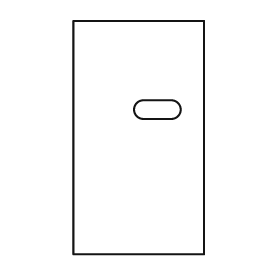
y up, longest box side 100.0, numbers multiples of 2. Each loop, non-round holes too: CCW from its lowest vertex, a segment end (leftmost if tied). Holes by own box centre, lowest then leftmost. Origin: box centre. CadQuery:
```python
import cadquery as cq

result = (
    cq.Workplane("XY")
    .moveTo(-28.0, -50.0)
    .lineTo(28.0, -50.0)
    .lineTo(28.0, 50.0)
    .lineTo(-28.0, 50.0)
    .close()
    .moveTo(2.0, 8.0)
    .lineTo(14.0, 8.0)
    .threePointArc((18.0, 12.0), (14.0, 16.0))
    .lineTo(2.0, 16.0)
    .threePointArc((-2.0, 12.0), (2.0, 8.0))
    .close()
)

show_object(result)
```